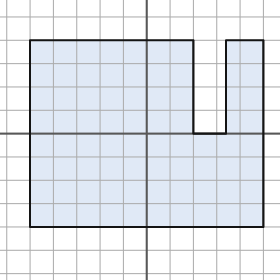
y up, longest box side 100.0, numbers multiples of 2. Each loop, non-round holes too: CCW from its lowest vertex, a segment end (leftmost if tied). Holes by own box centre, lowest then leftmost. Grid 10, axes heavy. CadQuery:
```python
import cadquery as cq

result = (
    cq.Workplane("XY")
    .moveTo(-50.0, -40.0)
    .lineTo(50.0, -40.0)
    .lineTo(50.0, 40.0)
    .lineTo(34.0, 40.0)
    .lineTo(34.0, 0.0)
    .lineTo(20.0, 0.0)
    .lineTo(20.0, 40.0)
    .lineTo(-50.0, 40.0)
    .close()
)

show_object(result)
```